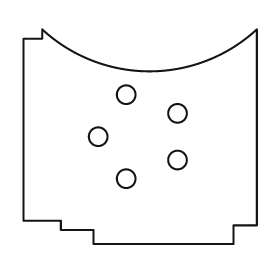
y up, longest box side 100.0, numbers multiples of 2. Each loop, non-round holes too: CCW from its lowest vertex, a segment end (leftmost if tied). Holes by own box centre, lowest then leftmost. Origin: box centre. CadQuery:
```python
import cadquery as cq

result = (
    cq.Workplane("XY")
    .moveTo(-20.0, -46.0)
    .lineTo(40.0, -46.0)
    .lineTo(40.0, -38.0)
    .lineTo(50.0, -38.0)
    .lineTo(50.0, 46.0)
    .threePointArc((4.0, 28.0), (-42.0, 46.0))
    .lineTo(-42.0, 42.0)
    .lineTo(-50.0, 42.0)
    .lineTo(-50.0, -36.0)
    .lineTo(-34.0, -36.0)
    .lineTo(-34.0, -40.0)
    .lineTo(-20.0, -40.0)
    .close()
    .moveTo(-6.0, -18.0)
    .circle(4.0)
    .moveTo(16.0, -10.0)
    .circle(4.0)
    .moveTo(-18.0, 0.0)
    .circle(4.0)
    .moveTo(16.0, 10.0)
    .circle(4.0)
    .moveTo(-6.0, 18.0)
    .circle(4.0)
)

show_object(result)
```